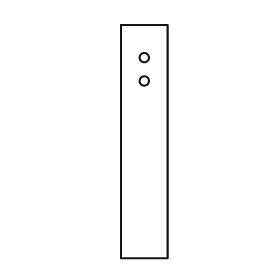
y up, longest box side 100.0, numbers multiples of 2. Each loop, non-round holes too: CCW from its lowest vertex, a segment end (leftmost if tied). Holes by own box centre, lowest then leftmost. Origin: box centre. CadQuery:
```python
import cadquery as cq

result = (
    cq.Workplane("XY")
    .moveTo(-10.0, -50.0)
    .lineTo(10.0, -50.0)
    .lineTo(10.0, 50.0)
    .lineTo(-10.0, 50.0)
    .close()
    .moveTo(0.0, 26.0)
    .circle(2.0)
    .moveTo(0.0, 36.0)
    .circle(2.0)
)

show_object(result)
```